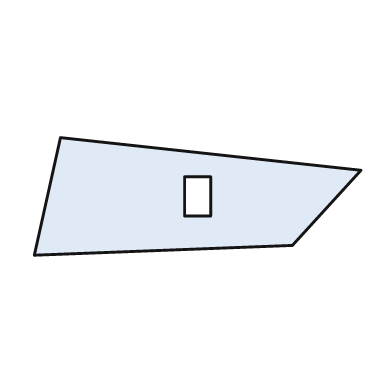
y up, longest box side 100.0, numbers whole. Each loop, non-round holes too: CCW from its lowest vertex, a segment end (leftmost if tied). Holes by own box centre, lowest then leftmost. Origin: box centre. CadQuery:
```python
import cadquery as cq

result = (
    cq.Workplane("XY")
    .moveTo(-50.0, -18.0)
    .lineTo(29.0, -15.0)
    .lineTo(50.0, 8.0)
    .lineTo(-42.0, 18.0)
    .close()
    .moveTo(-4.0, -6.0)
    .lineTo(4.0, -6.0)
    .lineTo(4.0, 6.0)
    .lineTo(-4.0, 6.0)
    .close()
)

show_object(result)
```